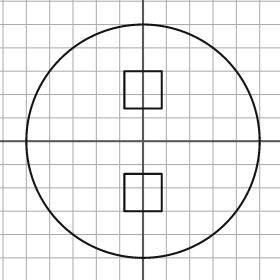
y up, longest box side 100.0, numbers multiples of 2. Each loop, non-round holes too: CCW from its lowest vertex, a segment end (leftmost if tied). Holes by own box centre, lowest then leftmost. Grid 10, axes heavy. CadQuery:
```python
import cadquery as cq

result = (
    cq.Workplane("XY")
    .moveTo(0.0, 0.0)
    .circle(50.0)
    .moveTo(-8.0, -30.0)
    .lineTo(8.0, -30.0)
    .lineTo(8.0, -14.0)
    .lineTo(-8.0, -14.0)
    .close()
    .moveTo(-8.0, 14.0)
    .lineTo(8.0, 14.0)
    .lineTo(8.0, 30.0)
    .lineTo(-8.0, 30.0)
    .close()
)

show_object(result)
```